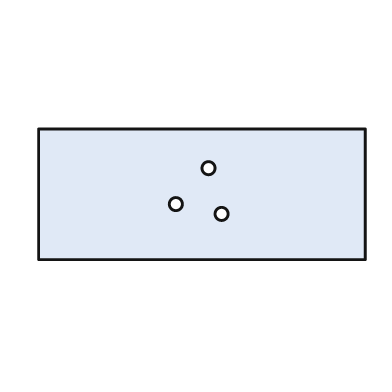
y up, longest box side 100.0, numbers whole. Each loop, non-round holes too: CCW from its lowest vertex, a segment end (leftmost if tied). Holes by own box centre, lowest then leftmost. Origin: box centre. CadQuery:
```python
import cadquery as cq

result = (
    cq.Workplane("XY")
    .moveTo(-50.0, -20.0)
    .lineTo(50.0, -20.0)
    .lineTo(50.0, 20.0)
    .lineTo(-50.0, 20.0)
    .close()
    .moveTo(6.0, -6.0)
    .circle(2.0)
    .moveTo(-8.0, -3.0)
    .circle(2.0)
    .moveTo(2.0, 8.0)
    .circle(2.0)
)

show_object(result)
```